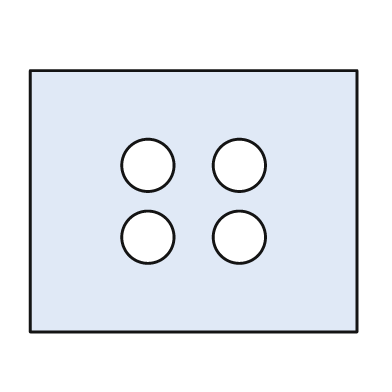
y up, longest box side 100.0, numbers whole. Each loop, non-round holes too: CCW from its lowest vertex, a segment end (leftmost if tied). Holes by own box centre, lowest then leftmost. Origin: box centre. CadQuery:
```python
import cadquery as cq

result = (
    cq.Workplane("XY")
    .moveTo(-50.0, -40.0)
    .lineTo(50.0, -40.0)
    .lineTo(50.0, 40.0)
    .lineTo(-50.0, 40.0)
    .close()
    .moveTo(-14.0, -11.0)
    .circle(8.0)
    .moveTo(14.0, -11.0)
    .circle(8.0)
    .moveTo(-14.0, 11.0)
    .circle(8.0)
    .moveTo(14.0, 11.0)
    .circle(8.0)
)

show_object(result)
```